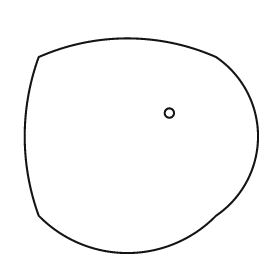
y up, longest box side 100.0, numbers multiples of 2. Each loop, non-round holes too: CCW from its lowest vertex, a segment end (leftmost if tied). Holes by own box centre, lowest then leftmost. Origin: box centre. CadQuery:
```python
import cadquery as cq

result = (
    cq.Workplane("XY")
    .moveTo(-44.0, -30.0)
    .threePointArc((-6.0, -46.0), (32.0, -30.0))
    .threePointArc((50.0, 4.0), (32.0, 38.0))
    .threePointArc((-6.0, 46.0), (-44.0, 38.0))
    .threePointArc((-50.0, 4.0), (-44.0, -30.0))
    .close()
    .moveTo(12.0, 14.0)
    .circle(2.0)
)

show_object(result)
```